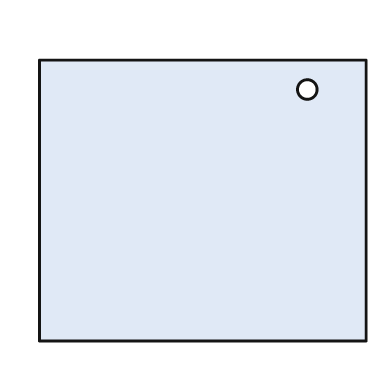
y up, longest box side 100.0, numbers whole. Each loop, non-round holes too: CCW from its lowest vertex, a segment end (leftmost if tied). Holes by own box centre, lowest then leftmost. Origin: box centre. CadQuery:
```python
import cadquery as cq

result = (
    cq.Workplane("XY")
    .moveTo(-50.0, -43.0)
    .lineTo(50.0, -43.0)
    .lineTo(50.0, 43.0)
    .lineTo(-50.0, 43.0)
    .close()
    .moveTo(32.0, 34.0)
    .circle(3.0)
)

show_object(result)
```